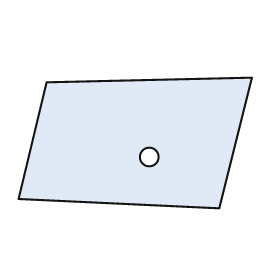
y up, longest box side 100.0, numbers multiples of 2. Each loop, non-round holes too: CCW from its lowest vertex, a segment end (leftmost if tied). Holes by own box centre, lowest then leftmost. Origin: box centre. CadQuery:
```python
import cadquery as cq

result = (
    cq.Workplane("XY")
    .moveTo(36.0, -28.0)
    .lineTo(50.0, 28.0)
    .lineTo(-38.0, 26.0)
    .lineTo(-50.0, -24.0)
    .close()
    .moveTo(6.0, -6.0)
    .circle(4.0)
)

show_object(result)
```